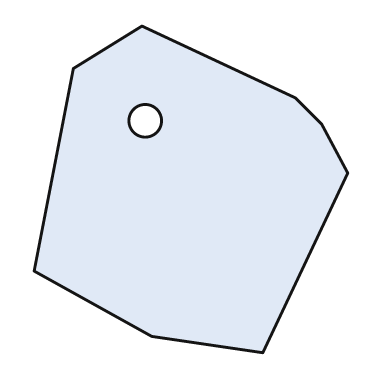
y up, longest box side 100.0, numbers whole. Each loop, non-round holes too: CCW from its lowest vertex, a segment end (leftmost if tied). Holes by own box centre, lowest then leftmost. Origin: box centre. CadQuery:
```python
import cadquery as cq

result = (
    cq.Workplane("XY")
    .moveTo(22.0, -50.0)
    .lineTo(48.0, 5.0)
    .lineTo(40.0, 20.0)
    .lineTo(32.0, 28.0)
    .lineTo(-15.0, 50.0)
    .lineTo(-36.0, 37.0)
    .lineTo(-48.0, -25.0)
    .lineTo(-12.0, -45.0)
    .close()
    .moveTo(-14.0, 21.0)
    .circle(5.0)
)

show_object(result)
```